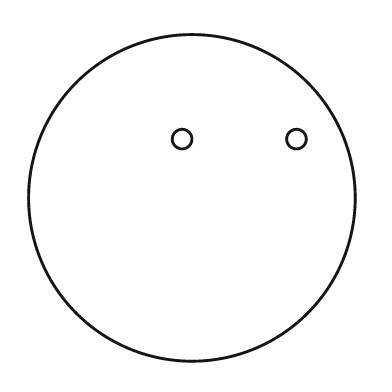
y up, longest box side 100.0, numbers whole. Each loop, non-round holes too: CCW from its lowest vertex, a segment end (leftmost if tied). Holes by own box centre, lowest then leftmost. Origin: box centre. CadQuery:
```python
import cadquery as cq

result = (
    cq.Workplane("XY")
    .moveTo(0.0, 0.0)
    .circle(50.0)
    .moveTo(-3.0, 18.0)
    .circle(3.0)
    .moveTo(32.0, 18.0)
    .circle(3.0)
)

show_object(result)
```